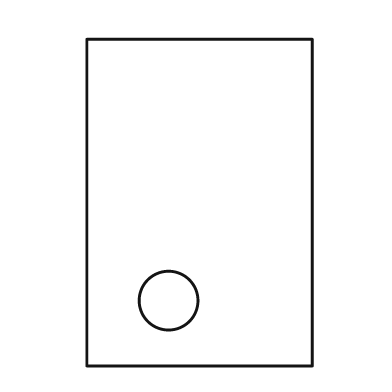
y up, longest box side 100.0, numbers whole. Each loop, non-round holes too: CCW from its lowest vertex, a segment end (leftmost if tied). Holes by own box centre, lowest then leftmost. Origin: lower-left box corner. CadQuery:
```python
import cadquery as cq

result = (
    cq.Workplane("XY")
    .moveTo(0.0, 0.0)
    .lineTo(69.0, 0.0)
    .lineTo(69.0, 100.0)
    .lineTo(0.0, 100.0)
    .close()
    .moveTo(25.0, 20.0)
    .circle(9.0)
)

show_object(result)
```